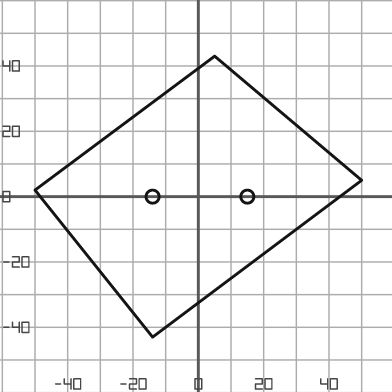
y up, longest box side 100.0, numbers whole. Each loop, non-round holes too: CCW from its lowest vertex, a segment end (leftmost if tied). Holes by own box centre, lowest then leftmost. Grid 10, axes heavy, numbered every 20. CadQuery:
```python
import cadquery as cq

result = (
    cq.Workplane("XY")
    .moveTo(-14.0, -43.0)
    .lineTo(50.0, 5.0)
    .lineTo(5.0, 43.0)
    .lineTo(-50.0, 2.0)
    .close()
    .moveTo(-14.0, 0.0)
    .circle(2.0)
    .moveTo(15.0, 0.0)
    .circle(2.0)
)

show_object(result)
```